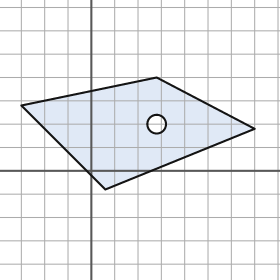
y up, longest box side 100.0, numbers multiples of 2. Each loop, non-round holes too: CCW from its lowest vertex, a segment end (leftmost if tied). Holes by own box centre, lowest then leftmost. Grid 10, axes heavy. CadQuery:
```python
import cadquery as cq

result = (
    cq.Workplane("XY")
    .moveTo(6.0, -8.0)
    .lineTo(70.0, 18.0)
    .lineTo(28.0, 40.0)
    .lineTo(-30.0, 28.0)
    .close()
    .moveTo(28.0, 20.0)
    .circle(4.0)
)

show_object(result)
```